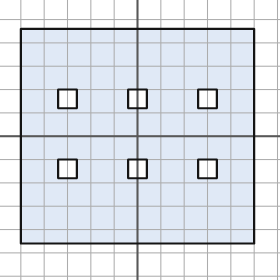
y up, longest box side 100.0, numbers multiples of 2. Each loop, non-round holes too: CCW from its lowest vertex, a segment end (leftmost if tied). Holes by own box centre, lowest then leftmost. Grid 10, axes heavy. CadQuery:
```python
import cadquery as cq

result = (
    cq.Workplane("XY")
    .moveTo(-50.0, -46.0)
    .lineTo(50.0, -46.0)
    .lineTo(50.0, 46.0)
    .lineTo(-50.0, 46.0)
    .close()
    .moveTo(-34.0, -18.0)
    .lineTo(-26.0, -18.0)
    .lineTo(-26.0, -10.0)
    .lineTo(-34.0, -10.0)
    .close()
    .moveTo(-4.0, -18.0)
    .lineTo(4.0, -18.0)
    .lineTo(4.0, -10.0)
    .lineTo(-4.0, -10.0)
    .close()
    .moveTo(26.0, -18.0)
    .lineTo(34.0, -18.0)
    .lineTo(34.0, -10.0)
    .lineTo(26.0, -10.0)
    .close()
    .moveTo(-34.0, 12.0)
    .lineTo(-26.0, 12.0)
    .lineTo(-26.0, 20.0)
    .lineTo(-34.0, 20.0)
    .close()
    .moveTo(-4.0, 12.0)
    .lineTo(4.0, 12.0)
    .lineTo(4.0, 20.0)
    .lineTo(-4.0, 20.0)
    .close()
    .moveTo(26.0, 12.0)
    .lineTo(34.0, 12.0)
    .lineTo(34.0, 20.0)
    .lineTo(26.0, 20.0)
    .close()
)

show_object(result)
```